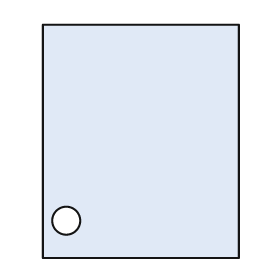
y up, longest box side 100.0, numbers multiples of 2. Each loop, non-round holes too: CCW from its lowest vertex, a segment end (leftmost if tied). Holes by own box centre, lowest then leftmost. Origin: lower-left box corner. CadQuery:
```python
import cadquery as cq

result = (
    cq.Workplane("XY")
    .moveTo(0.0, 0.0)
    .lineTo(84.0, 0.0)
    .lineTo(84.0, 100.0)
    .lineTo(0.0, 100.0)
    .close()
    .moveTo(10.0, 16.0)
    .circle(6.0)
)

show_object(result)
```